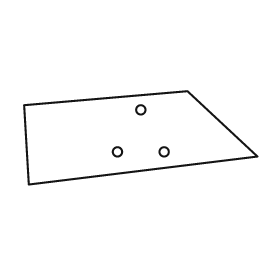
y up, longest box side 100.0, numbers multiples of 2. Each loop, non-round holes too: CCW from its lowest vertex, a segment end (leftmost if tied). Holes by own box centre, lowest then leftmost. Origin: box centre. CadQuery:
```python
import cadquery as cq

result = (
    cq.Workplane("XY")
    .moveTo(-48.0, -20.0)
    .lineTo(50.0, -8.0)
    .lineTo(20.0, 20.0)
    .lineTo(-50.0, 14.0)
    .close()
    .moveTo(-10.0, -6.0)
    .circle(2.0)
    .moveTo(10.0, -6.0)
    .circle(2.0)
    .moveTo(0.0, 12.0)
    .circle(2.0)
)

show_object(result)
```